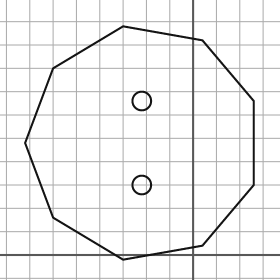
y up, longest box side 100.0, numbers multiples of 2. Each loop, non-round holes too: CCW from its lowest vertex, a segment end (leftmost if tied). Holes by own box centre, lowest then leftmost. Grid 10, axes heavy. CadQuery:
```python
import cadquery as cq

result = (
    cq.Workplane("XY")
    .moveTo(-30.0, -2.0)
    .lineTo(4.0, 4.0)
    .lineTo(26.0, 30.0)
    .lineTo(26.0, 66.0)
    .lineTo(4.0, 92.0)
    .lineTo(-30.0, 98.0)
    .lineTo(-60.0, 80.0)
    .lineTo(-72.0, 48.0)
    .lineTo(-60.0, 16.0)
    .close()
    .moveTo(-22.0, 30.0)
    .circle(4.0)
    .moveTo(-22.0, 66.0)
    .circle(4.0)
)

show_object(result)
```